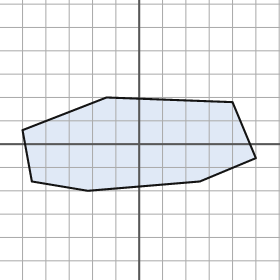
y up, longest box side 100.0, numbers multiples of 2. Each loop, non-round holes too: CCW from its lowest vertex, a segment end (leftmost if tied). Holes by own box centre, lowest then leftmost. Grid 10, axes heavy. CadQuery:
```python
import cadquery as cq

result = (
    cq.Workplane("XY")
    .moveTo(-22.0, -20.0)
    .lineTo(26.0, -16.0)
    .lineTo(50.0, -6.0)
    .lineTo(40.0, 18.0)
    .lineTo(-14.0, 20.0)
    .lineTo(-50.0, 6.0)
    .lineTo(-46.0, -16.0)
    .close()
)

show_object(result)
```